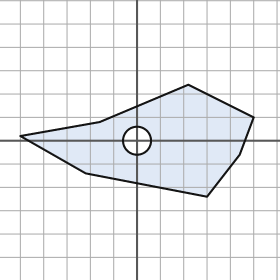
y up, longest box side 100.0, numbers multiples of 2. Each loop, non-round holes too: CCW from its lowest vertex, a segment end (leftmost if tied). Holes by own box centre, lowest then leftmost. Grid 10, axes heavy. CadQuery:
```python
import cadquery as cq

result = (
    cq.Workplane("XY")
    .moveTo(30.0, -24.0)
    .lineTo(44.0, -6.0)
    .lineTo(50.0, 10.0)
    .lineTo(22.0, 24.0)
    .lineTo(-16.0, 8.0)
    .lineTo(-50.0, 2.0)
    .lineTo(-22.0, -14.0)
    .close()
    .moveTo(0.0, 0.0)
    .circle(6.0)
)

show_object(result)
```